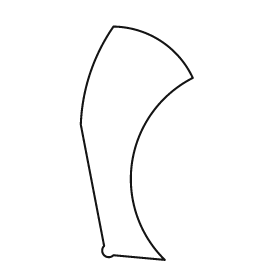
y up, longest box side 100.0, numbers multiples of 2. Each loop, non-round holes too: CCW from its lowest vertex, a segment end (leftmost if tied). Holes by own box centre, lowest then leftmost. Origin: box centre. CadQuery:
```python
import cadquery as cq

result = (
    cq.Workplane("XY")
    .moveTo(12.0, -50.0)
    .threePointArc((-2.0, -8.0), (24.0, 28.0))
    .threePointArc((10.0, 44.0), (-10.0, 50.0))
    .threePointArc((-20.0, 30.0), (-24.0, 8.0))
    .lineTo(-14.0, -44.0)
    .threePointArc((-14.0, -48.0), (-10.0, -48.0))
    .close()
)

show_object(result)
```